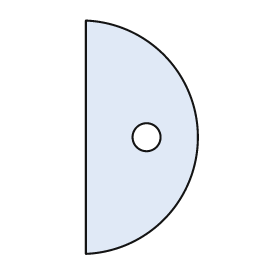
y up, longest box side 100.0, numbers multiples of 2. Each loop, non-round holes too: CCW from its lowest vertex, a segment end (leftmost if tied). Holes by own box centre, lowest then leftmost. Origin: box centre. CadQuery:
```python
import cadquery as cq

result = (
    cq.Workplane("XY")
    .moveTo(-24.0, -50.0)
    .threePointArc((24.0, 0.0), (-24.0, 50.0))
    .close()
    .moveTo(2.0, 0.0)
    .circle(6.0)
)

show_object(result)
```